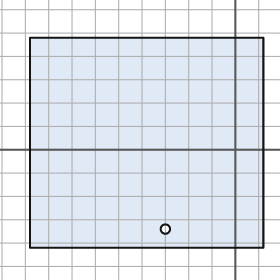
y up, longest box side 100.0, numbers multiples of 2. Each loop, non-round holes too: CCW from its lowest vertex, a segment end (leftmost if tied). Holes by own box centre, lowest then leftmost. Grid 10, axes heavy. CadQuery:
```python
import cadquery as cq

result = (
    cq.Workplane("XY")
    .moveTo(-88.0, -42.0)
    .lineTo(12.0, -42.0)
    .lineTo(12.0, 48.0)
    .lineTo(-88.0, 48.0)
    .close()
    .moveTo(-30.0, -34.0)
    .circle(2.0)
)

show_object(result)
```